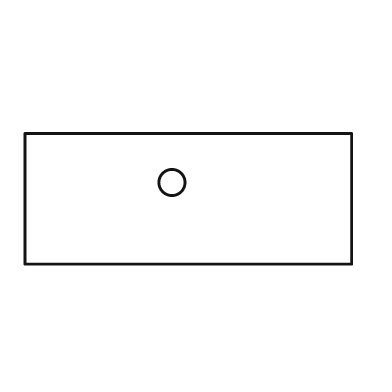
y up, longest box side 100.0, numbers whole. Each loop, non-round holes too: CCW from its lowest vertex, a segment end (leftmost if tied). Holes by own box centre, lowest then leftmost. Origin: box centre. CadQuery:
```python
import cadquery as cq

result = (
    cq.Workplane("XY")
    .moveTo(-50.0, -20.0)
    .lineTo(50.0, -20.0)
    .lineTo(50.0, 20.0)
    .lineTo(-50.0, 20.0)
    .close()
    .moveTo(-5.0, 5.0)
    .circle(4.0)
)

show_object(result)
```